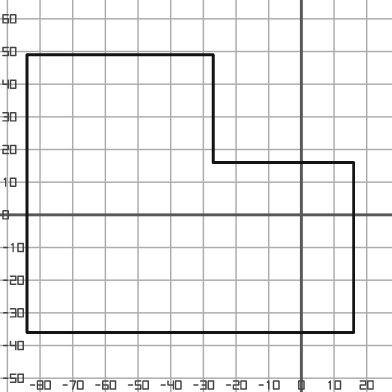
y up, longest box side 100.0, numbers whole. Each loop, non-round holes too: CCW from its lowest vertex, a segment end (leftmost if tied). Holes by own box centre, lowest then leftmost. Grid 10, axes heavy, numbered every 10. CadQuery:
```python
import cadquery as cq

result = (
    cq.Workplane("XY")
    .moveTo(-84.0, -36.0)
    .lineTo(16.0, -36.0)
    .lineTo(16.0, 16.0)
    .lineTo(-27.0, 16.0)
    .lineTo(-27.0, 49.0)
    .lineTo(-84.0, 49.0)
    .close()
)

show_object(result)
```